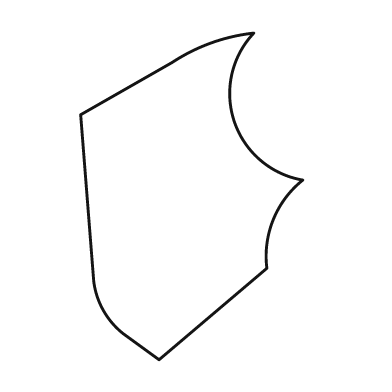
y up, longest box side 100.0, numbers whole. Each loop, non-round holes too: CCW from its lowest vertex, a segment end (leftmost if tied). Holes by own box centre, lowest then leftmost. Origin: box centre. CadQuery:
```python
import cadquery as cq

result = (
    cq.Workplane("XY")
    .moveTo(-10.0, -50.0)
    .lineTo(23.0, -22.0)
    .threePointArc((25.0, -7.0), (34.0, 5.0))
    .threePointArc((13.0, 23.0), (19.0, 50.0))
    .threePointArc((6.0, 47.0), (-6.0, 41.0))
    .lineTo(-34.0, 25.0)
    .lineTo(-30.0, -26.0)
    .threePointArc((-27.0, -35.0), (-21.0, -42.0))
    .close()
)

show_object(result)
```